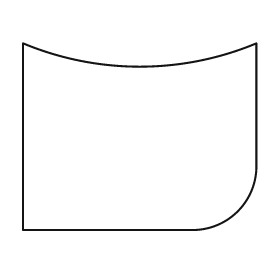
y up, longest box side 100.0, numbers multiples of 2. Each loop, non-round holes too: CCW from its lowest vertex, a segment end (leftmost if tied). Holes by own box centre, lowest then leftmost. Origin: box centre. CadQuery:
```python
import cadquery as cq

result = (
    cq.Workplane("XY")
    .moveTo(-50.0, -40.0)
    .lineTo(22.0, -40.0)
    .threePointArc((42.0, -32.0), (50.0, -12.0))
    .lineTo(50.0, 40.0)
    .threePointArc((0.0, 30.0), (-50.0, 40.0))
    .close()
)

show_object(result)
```